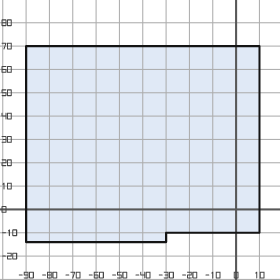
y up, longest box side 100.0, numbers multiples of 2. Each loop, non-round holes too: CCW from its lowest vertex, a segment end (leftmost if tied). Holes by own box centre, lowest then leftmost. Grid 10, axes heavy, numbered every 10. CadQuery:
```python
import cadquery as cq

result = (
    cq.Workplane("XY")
    .moveTo(-90.0, -14.0)
    .lineTo(-30.0, -14.0)
    .lineTo(-30.0, -10.0)
    .lineTo(10.0, -10.0)
    .lineTo(10.0, 70.0)
    .lineTo(-90.0, 70.0)
    .close()
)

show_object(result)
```